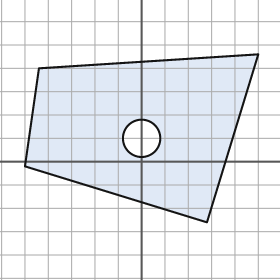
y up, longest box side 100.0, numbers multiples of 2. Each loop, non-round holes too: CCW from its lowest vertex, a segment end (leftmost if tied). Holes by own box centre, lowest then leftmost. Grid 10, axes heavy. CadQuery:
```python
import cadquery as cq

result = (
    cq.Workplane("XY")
    .moveTo(28.0, -26.0)
    .lineTo(50.0, 46.0)
    .lineTo(-44.0, 40.0)
    .lineTo(-50.0, -2.0)
    .close()
    .moveTo(0.0, 10.0)
    .circle(8.0)
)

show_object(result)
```